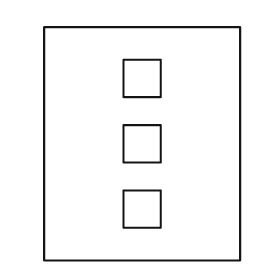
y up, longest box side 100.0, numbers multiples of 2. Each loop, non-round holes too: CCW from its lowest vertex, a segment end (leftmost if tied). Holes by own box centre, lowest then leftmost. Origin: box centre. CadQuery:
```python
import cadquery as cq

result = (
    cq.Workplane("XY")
    .moveTo(-42.0, -50.0)
    .lineTo(42.0, -50.0)
    .lineTo(42.0, 50.0)
    .lineTo(-42.0, 50.0)
    .close()
    .moveTo(-8.0, -36.0)
    .lineTo(8.0, -36.0)
    .lineTo(8.0, -20.0)
    .lineTo(-8.0, -20.0)
    .close()
    .moveTo(-8.0, -8.0)
    .lineTo(8.0, -8.0)
    .lineTo(8.0, 8.0)
    .lineTo(-8.0, 8.0)
    .close()
    .moveTo(-8.0, 20.0)
    .lineTo(8.0, 20.0)
    .lineTo(8.0, 36.0)
    .lineTo(-8.0, 36.0)
    .close()
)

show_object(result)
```